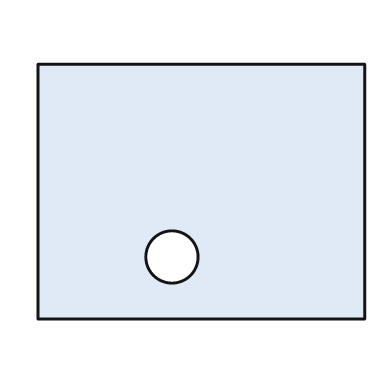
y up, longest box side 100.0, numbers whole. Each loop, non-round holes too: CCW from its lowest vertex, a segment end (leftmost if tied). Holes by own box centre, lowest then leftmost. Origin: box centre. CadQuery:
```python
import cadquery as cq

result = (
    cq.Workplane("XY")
    .moveTo(-50.0, -39.0)
    .lineTo(50.0, -39.0)
    .lineTo(50.0, 39.0)
    .lineTo(-50.0, 39.0)
    .close()
    .moveTo(-9.0, -20.0)
    .circle(8.0)
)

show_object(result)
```